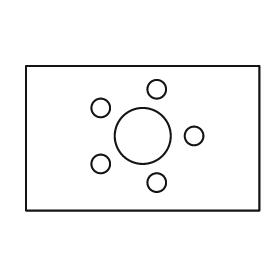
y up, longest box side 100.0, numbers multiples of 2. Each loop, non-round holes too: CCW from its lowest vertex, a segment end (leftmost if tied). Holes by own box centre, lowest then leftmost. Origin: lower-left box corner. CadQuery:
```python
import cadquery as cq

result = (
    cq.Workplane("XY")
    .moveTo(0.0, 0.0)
    .lineTo(100.0, 0.0)
    .lineTo(100.0, 62.0)
    .lineTo(0.0, 62.0)
    .close()
    .moveTo(56.0, 12.0)
    .circle(4.0)
    .moveTo(32.0, 20.0)
    .circle(4.0)
    .moveTo(50.0, 32.0)
    .circle(12.0)
    .moveTo(72.0, 32.0)
    .circle(4.0)
    .moveTo(32.0, 44.0)
    .circle(4.0)
    .moveTo(56.0, 52.0)
    .circle(4.0)
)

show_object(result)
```